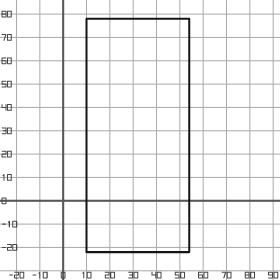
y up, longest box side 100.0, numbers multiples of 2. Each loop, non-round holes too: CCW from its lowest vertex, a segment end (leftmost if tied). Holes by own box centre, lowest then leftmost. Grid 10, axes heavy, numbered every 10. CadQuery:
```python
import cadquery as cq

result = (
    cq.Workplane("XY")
    .moveTo(10.0, -22.0)
    .lineTo(54.0, -22.0)
    .lineTo(54.0, 78.0)
    .lineTo(10.0, 78.0)
    .close()
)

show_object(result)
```